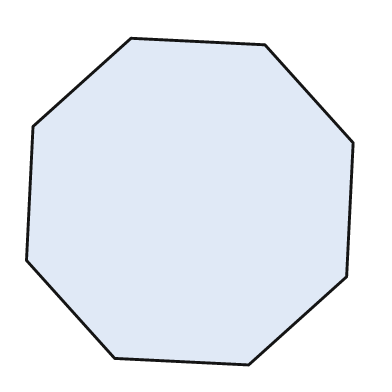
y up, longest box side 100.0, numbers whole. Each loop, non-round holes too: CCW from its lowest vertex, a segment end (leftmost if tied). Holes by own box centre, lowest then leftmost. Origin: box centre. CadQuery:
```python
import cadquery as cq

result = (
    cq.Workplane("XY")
    .moveTo(18.0, -50.0)
    .lineTo(48.0, -23.0)
    .lineTo(50.0, 18.0)
    .lineTo(23.0, 48.0)
    .lineTo(-18.0, 50.0)
    .lineTo(-48.0, 23.0)
    .lineTo(-50.0, -18.0)
    .lineTo(-23.0, -48.0)
    .close()
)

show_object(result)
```